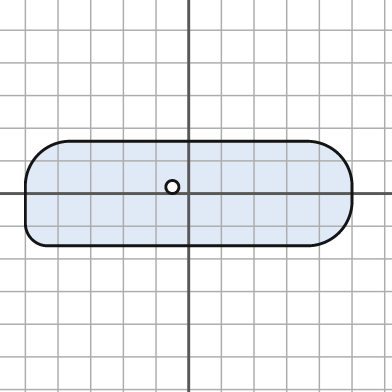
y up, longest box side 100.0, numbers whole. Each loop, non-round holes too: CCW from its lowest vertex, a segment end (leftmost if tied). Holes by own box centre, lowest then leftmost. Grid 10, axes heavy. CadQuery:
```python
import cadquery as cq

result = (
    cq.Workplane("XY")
    .moveTo(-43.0, -16.0)
    .lineTo(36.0, -16.0)
    .threePointArc((46.0, -12.0), (50.0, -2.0))
    .lineTo(50.0, 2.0)
    .threePointArc((46.0, 12.0), (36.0, 16.0))
    .lineTo(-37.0, 16.0)
    .threePointArc((-46.0, 12.0), (-50.0, 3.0))
    .lineTo(-50.0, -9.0)
    .threePointArc((-48.0, -14.0), (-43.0, -16.0))
    .close()
    .moveTo(-5.0, 2.0)
    .circle(2.0)
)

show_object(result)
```